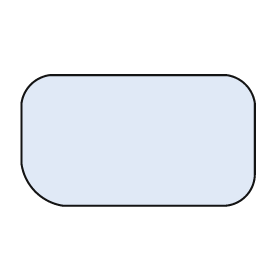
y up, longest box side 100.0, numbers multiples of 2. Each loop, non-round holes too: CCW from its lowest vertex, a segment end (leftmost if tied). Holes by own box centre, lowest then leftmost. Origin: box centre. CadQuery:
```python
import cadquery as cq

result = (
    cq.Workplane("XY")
    .moveTo(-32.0, -28.0)
    .lineTo(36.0, -28.0)
    .threePointArc((46.0, -24.0), (50.0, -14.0))
    .lineTo(50.0, 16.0)
    .threePointArc((46.0, 24.0), (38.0, 28.0))
    .lineTo(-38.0, 28.0)
    .threePointArc((-46.0, 24.0), (-50.0, 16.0))
    .lineTo(-50.0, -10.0)
    .threePointArc((-44.0, -22.0), (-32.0, -28.0))
    .close()
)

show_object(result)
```